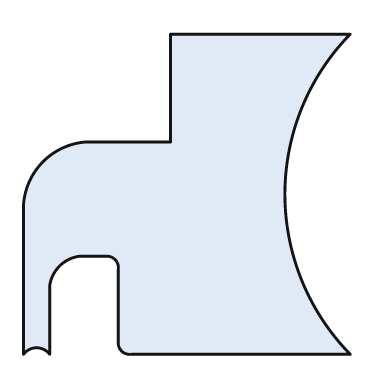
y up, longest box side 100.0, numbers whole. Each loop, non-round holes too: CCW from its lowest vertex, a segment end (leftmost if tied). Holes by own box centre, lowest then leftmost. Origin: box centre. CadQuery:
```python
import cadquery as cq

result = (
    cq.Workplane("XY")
    .moveTo(-50.0, -49.0)
    .threePointArc((-46.0, -47.0), (-42.0, -49.0))
    .lineTo(-42.0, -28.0)
    .threePointArc((-39.0, -22.0), (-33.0, -19.0))
    .lineTo(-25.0, -19.0)
    .threePointArc((-22.0, -20.0), (-21.0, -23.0))
    .lineTo(-21.0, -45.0)
    .threePointArc((-20.0, -48.0), (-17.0, -49.0))
    .lineTo(50.0, -49.0)
    .threePointArc((30.0, 0.0), (50.0, 49.0))
    .lineTo(-5.0, 49.0)
    .lineTo(-5.0, 16.0)
    .lineTo(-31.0, 16.0)
    .threePointArc((-44.0, 10.0), (-50.0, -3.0))
    .close()
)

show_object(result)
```